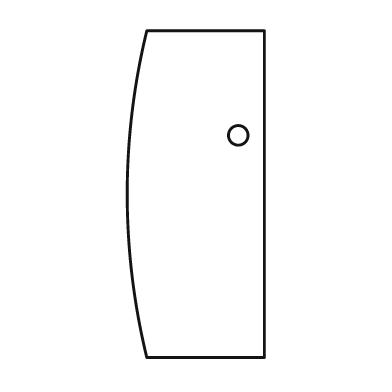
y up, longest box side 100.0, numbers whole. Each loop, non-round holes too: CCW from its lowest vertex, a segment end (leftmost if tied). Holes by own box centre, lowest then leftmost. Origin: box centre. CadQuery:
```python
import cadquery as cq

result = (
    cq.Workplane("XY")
    .moveTo(-15.0, -50.0)
    .lineTo(21.0, -50.0)
    .lineTo(21.0, 50.0)
    .lineTo(-15.0, 50.0)
    .threePointArc((-21.0, 0.0), (-15.0, -50.0))
    .close()
    .moveTo(13.0, 18.0)
    .circle(3.0)
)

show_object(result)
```